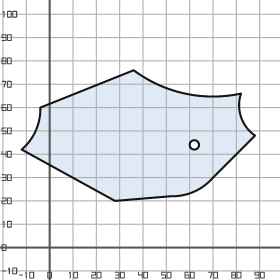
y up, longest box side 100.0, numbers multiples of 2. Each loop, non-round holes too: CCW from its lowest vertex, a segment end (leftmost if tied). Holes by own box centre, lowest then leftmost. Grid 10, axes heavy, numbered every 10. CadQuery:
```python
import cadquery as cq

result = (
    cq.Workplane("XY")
    .moveTo(28.0, 20.0)
    .lineTo(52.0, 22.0)
    .threePointArc((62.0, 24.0), (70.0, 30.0))
    .lineTo(88.0, 48.0)
    .threePointArc((82.0, 56.0), (82.0, 66.0))
    .threePointArc((58.0, 66.0), (36.0, 76.0))
    .lineTo(-4.0, 60.0)
    .threePointArc((-6.0, 50.0), (-12.0, 42.0))
    .close()
    .moveTo(62.0, 44.0)
    .circle(2.0)
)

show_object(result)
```